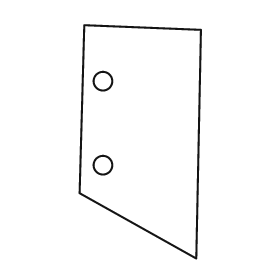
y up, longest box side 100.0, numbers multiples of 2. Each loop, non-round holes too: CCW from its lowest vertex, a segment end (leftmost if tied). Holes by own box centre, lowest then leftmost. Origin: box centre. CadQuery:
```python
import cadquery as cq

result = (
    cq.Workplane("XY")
    .moveTo(24.0, -50.0)
    .lineTo(26.0, 48.0)
    .lineTo(-24.0, 50.0)
    .lineTo(-26.0, -22.0)
    .close()
    .moveTo(-16.0, -10.0)
    .circle(4.0)
    .moveTo(-16.0, 26.0)
    .circle(4.0)
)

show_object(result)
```